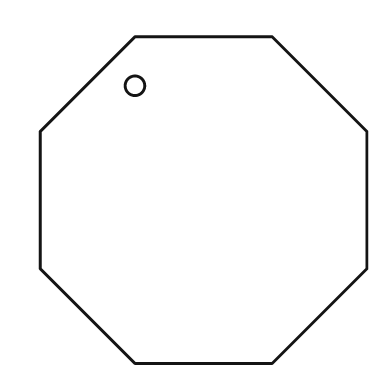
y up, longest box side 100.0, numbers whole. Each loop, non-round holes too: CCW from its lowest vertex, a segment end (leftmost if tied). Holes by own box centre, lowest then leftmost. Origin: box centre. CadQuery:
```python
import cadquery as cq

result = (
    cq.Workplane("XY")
    .moveTo(-21.0, -50.0)
    .lineTo(21.0, -50.0)
    .lineTo(50.0, -21.0)
    .lineTo(50.0, 21.0)
    .lineTo(21.0, 50.0)
    .lineTo(-21.0, 50.0)
    .lineTo(-50.0, 21.0)
    .lineTo(-50.0, -21.0)
    .close()
    .moveTo(-21.0, 35.0)
    .circle(3.0)
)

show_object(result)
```